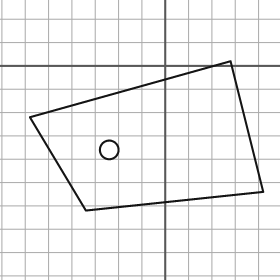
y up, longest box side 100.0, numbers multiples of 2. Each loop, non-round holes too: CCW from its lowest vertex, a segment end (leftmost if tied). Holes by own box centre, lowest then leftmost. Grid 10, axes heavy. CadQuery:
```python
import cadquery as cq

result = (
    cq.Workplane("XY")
    .moveTo(-34.0, -62.0)
    .lineTo(42.0, -54.0)
    .lineTo(28.0, 2.0)
    .lineTo(-58.0, -22.0)
    .close()
    .moveTo(-24.0, -36.0)
    .circle(4.0)
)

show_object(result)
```